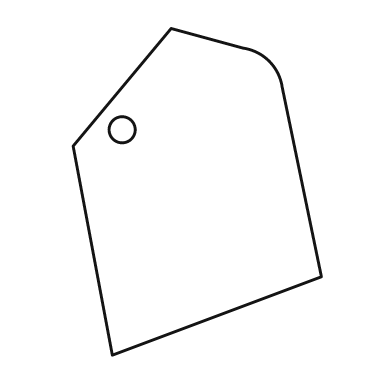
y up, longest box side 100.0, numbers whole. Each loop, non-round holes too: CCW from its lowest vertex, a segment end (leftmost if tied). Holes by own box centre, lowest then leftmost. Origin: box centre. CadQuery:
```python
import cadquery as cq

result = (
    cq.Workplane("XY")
    .moveTo(-26.0, -50.0)
    .lineTo(38.0, -26.0)
    .lineTo(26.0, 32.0)
    .threePointArc((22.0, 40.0), (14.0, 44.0))
    .lineTo(-8.0, 50.0)
    .lineTo(-38.0, 14.0)
    .close()
    .moveTo(-23.0, 19.0)
    .circle(4.0)
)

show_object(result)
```